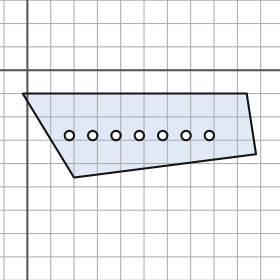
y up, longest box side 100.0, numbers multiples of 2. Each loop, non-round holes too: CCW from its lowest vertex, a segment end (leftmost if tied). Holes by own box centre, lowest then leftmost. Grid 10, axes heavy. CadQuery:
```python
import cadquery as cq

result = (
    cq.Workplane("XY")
    .moveTo(20.0, -46.0)
    .lineTo(98.0, -36.0)
    .lineTo(94.0, -10.0)
    .lineTo(-2.0, -10.0)
    .close()
    .moveTo(18.0, -28.0)
    .circle(2.0)
    .moveTo(28.0, -28.0)
    .circle(2.0)
    .moveTo(38.0, -28.0)
    .circle(2.0)
    .moveTo(48.0, -28.0)
    .circle(2.0)
    .moveTo(58.0, -28.0)
    .circle(2.0)
    .moveTo(68.0, -28.0)
    .circle(2.0)
    .moveTo(78.0, -28.0)
    .circle(2.0)
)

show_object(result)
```